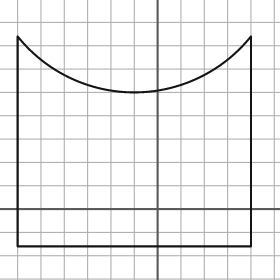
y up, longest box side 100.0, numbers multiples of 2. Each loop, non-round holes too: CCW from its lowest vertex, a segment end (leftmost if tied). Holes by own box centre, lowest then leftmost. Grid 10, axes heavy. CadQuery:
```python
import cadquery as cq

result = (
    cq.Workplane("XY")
    .moveTo(-60.0, -16.0)
    .lineTo(40.0, -16.0)
    .lineTo(40.0, 74.0)
    .threePointArc((-10.0, 50.0), (-60.0, 74.0))
    .close()
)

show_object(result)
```